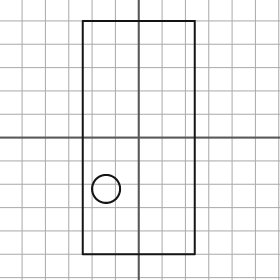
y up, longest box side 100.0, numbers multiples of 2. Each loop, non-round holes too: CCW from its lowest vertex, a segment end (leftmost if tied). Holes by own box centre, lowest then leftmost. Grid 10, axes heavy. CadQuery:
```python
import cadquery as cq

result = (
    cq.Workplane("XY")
    .moveTo(-24.0, -50.0)
    .lineTo(24.0, -50.0)
    .lineTo(24.0, 50.0)
    .lineTo(-24.0, 50.0)
    .close()
    .moveTo(-14.0, -22.0)
    .circle(6.0)
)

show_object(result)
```